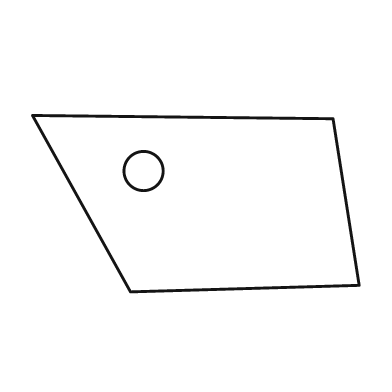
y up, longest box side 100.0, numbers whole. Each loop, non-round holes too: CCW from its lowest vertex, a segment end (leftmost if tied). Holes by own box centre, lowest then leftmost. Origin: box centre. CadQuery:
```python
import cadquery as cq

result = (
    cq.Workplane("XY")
    .moveTo(-20.0, -27.0)
    .lineTo(50.0, -25.0)
    .lineTo(42.0, 26.0)
    .lineTo(-50.0, 27.0)
    .close()
    .moveTo(-16.0, 10.0)
    .circle(6.0)
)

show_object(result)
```